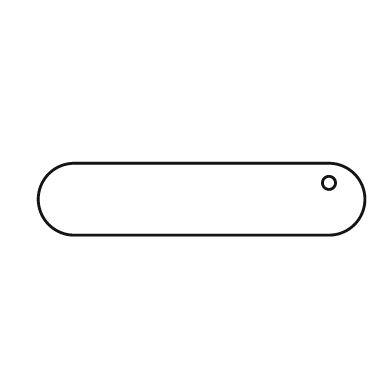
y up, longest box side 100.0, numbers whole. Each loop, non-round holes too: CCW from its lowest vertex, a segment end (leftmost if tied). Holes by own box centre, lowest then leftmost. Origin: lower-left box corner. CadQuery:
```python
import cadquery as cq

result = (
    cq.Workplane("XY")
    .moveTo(11.0, 0.0)
    .lineTo(89.0, 0.0)
    .threePointArc((100.0, 11.0), (89.0, 22.0))
    .lineTo(11.0, 22.0)
    .threePointArc((0.0, 11.0), (11.0, 0.0))
    .close()
    .moveTo(89.0, 16.0)
    .circle(2.0)
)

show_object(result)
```